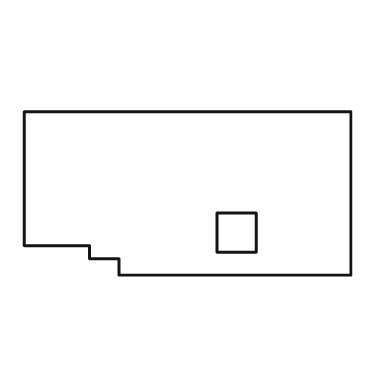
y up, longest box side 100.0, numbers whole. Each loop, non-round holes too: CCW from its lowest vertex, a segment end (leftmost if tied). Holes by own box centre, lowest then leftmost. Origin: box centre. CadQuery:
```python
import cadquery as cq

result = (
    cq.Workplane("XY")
    .moveTo(-21.0, -25.0)
    .lineTo(50.0, -25.0)
    .lineTo(50.0, 25.0)
    .lineTo(-50.0, 25.0)
    .lineTo(-50.0, -16.0)
    .lineTo(-30.0, -16.0)
    .lineTo(-30.0, -20.0)
    .lineTo(-21.0, -20.0)
    .close()
    .moveTo(9.0, -18.0)
    .lineTo(21.0, -18.0)
    .lineTo(21.0, -6.0)
    .lineTo(9.0, -6.0)
    .close()
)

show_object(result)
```